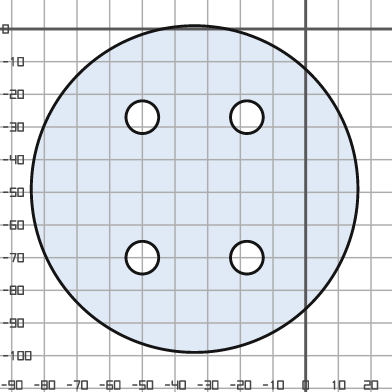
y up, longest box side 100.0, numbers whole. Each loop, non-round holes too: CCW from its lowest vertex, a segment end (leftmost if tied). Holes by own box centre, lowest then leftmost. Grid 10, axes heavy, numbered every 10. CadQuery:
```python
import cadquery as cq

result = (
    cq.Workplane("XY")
    .moveTo(-34.0, -49.0)
    .circle(50.0)
    .moveTo(-50.0, -70.0)
    .circle(5.0)
    .moveTo(-18.0, -70.0)
    .circle(5.0)
    .moveTo(-50.0, -27.0)
    .circle(5.0)
    .moveTo(-18.0, -27.0)
    .circle(5.0)
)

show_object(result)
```